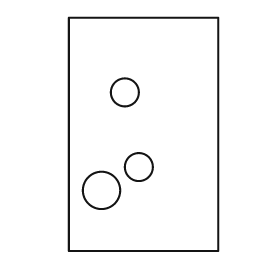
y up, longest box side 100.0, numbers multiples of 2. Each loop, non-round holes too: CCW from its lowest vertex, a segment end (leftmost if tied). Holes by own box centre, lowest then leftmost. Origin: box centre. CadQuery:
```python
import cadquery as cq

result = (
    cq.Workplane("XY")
    .moveTo(-32.0, -50.0)
    .lineTo(32.0, -50.0)
    .lineTo(32.0, 50.0)
    .lineTo(-32.0, 50.0)
    .close()
    .moveTo(-18.0, -24.0)
    .circle(8.0)
    .moveTo(-2.0, -14.0)
    .circle(6.0)
    .moveTo(-8.0, 18.0)
    .circle(6.0)
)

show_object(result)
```